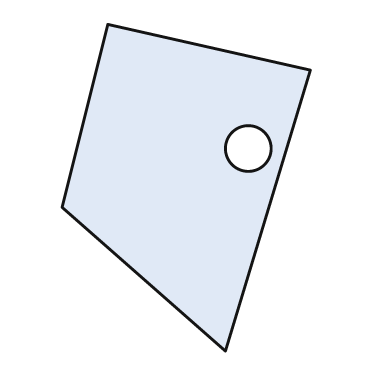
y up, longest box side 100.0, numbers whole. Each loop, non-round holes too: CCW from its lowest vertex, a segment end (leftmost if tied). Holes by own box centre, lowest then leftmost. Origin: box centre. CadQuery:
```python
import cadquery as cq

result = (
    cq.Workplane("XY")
    .moveTo(12.0, -50.0)
    .lineTo(38.0, 36.0)
    .lineTo(-24.0, 50.0)
    .lineTo(-38.0, -6.0)
    .close()
    .moveTo(19.0, 12.0)
    .circle(7.0)
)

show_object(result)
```